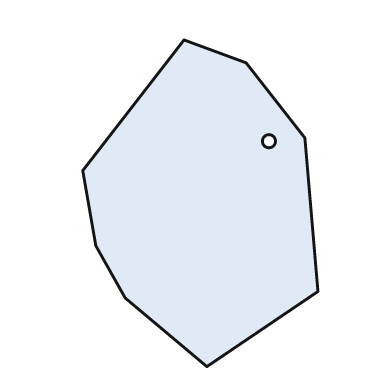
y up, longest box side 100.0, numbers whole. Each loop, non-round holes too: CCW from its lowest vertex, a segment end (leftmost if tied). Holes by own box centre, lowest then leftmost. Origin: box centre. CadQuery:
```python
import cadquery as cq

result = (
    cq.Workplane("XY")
    .moveTo(2.0, -50.0)
    .lineTo(36.0, -27.0)
    .lineTo(32.0, 20.0)
    .lineTo(14.0, 43.0)
    .lineTo(-5.0, 50.0)
    .lineTo(-36.0, 10.0)
    .lineTo(-32.0, -13.0)
    .lineTo(-23.0, -29.0)
    .close()
    .moveTo(21.0, 19.0)
    .circle(2.0)
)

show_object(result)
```